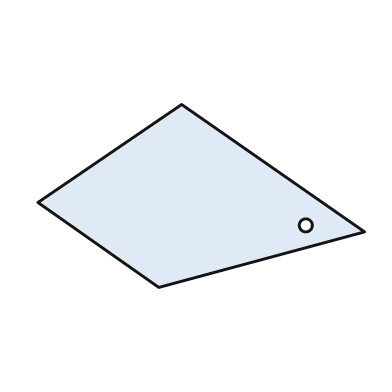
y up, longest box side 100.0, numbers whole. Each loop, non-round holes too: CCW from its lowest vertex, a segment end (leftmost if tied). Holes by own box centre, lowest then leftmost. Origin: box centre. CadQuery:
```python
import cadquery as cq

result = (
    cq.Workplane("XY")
    .moveTo(-13.0, -28.0)
    .lineTo(50.0, -11.0)
    .lineTo(-6.0, 28.0)
    .lineTo(-50.0, -2.0)
    .close()
    .moveTo(32.0, -9.0)
    .circle(2.0)
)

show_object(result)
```